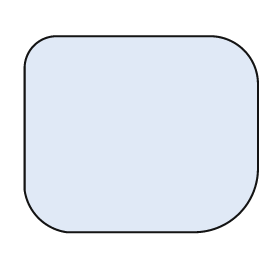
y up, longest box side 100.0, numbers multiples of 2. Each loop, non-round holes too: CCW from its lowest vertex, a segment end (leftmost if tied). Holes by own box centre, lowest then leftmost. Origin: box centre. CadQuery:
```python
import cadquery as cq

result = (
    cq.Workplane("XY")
    .moveTo(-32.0, -42.0)
    .lineTo(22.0, -42.0)
    .threePointArc((42.0, -34.0), (50.0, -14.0))
    .lineTo(50.0, 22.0)
    .threePointArc((44.0, 36.0), (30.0, 42.0))
    .lineTo(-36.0, 42.0)
    .threePointArc((-46.0, 38.0), (-50.0, 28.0))
    .lineTo(-50.0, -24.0)
    .threePointArc((-44.0, -36.0), (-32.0, -42.0))
    .close()
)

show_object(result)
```